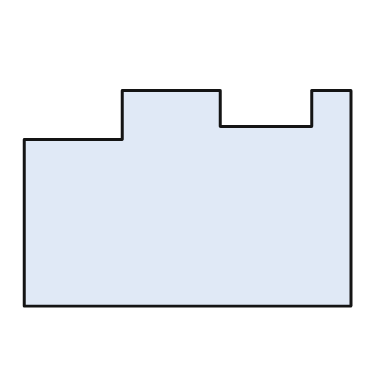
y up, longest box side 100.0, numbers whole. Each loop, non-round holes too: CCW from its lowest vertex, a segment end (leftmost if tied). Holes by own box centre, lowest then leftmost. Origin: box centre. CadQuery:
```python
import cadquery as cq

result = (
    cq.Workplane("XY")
    .moveTo(-50.0, -33.0)
    .lineTo(50.0, -33.0)
    .lineTo(50.0, 33.0)
    .lineTo(38.0, 33.0)
    .lineTo(38.0, 22.0)
    .lineTo(10.0, 22.0)
    .lineTo(10.0, 33.0)
    .lineTo(-20.0, 33.0)
    .lineTo(-20.0, 18.0)
    .lineTo(-50.0, 18.0)
    .close()
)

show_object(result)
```